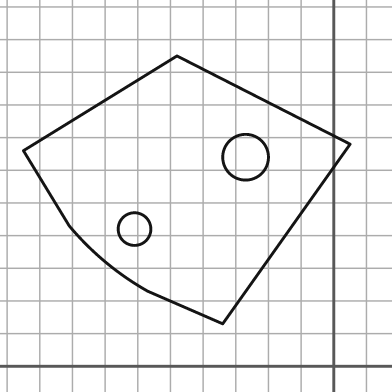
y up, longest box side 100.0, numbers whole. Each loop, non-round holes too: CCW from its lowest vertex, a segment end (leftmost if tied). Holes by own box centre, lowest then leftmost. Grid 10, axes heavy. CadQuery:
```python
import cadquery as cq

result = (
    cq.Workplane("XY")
    .moveTo(-34.0, 13.0)
    .lineTo(5.0, 68.0)
    .lineTo(-48.0, 95.0)
    .lineTo(-95.0, 66.0)
    .lineTo(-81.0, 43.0)
    .threePointArc((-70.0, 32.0), (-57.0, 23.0))
    .close()
    .moveTo(-61.0, 42.0)
    .circle(5.0)
    .moveTo(-27.0, 64.0)
    .circle(7.0)
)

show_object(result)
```